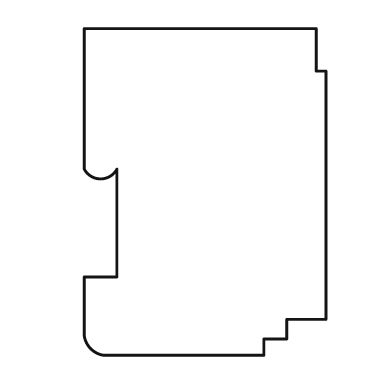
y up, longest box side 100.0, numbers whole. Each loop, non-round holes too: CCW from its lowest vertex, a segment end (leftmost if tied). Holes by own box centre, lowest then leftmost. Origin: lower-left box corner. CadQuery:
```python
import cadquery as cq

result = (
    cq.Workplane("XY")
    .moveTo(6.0, 0.0)
    .lineTo(55.0, 0.0)
    .lineTo(55.0, 5.0)
    .lineTo(62.0, 5.0)
    .lineTo(62.0, 11.0)
    .lineTo(74.0, 11.0)
    .lineTo(74.0, 87.0)
    .lineTo(71.0, 87.0)
    .lineTo(71.0, 100.0)
    .lineTo(0.0, 100.0)
    .lineTo(0.0, 57.0)
    .threePointArc((5.0, 54.0), (10.0, 57.0))
    .lineTo(10.0, 24.0)
    .lineTo(0.0, 24.0)
    .lineTo(0.0, 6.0)
    .threePointArc((2.0, 2.0), (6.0, 0.0))
    .close()
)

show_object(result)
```